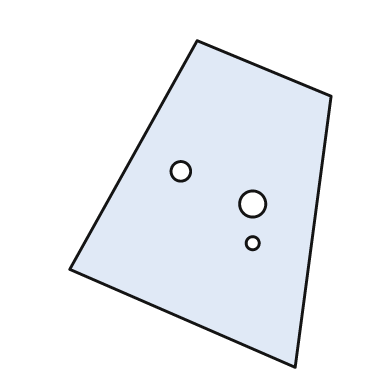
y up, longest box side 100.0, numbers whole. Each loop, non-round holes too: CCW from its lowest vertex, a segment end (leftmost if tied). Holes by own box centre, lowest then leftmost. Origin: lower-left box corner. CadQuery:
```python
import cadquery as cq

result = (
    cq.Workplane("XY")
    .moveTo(69.0, 0.0)
    .lineTo(80.0, 83.0)
    .lineTo(39.0, 100.0)
    .lineTo(0.0, 30.0)
    .close()
    .moveTo(56.0, 38.0)
    .circle(2.0)
    .moveTo(56.0, 50.0)
    .circle(4.0)
    .moveTo(34.0, 60.0)
    .circle(3.0)
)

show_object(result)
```